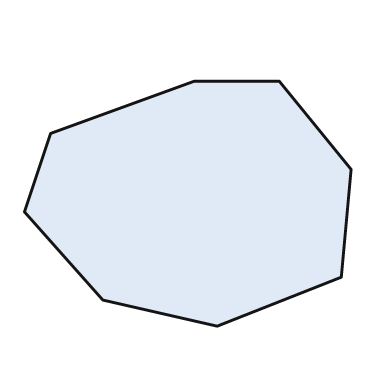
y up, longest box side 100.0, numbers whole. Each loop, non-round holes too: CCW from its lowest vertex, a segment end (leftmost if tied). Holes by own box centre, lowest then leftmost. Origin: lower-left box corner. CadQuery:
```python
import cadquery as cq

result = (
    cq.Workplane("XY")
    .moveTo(59.0, 0.0)
    .lineTo(97.0, 15.0)
    .lineTo(100.0, 48.0)
    .lineTo(78.0, 75.0)
    .lineTo(52.0, 75.0)
    .lineTo(8.0, 59.0)
    .lineTo(0.0, 35.0)
    .lineTo(24.0, 8.0)
    .close()
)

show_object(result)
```